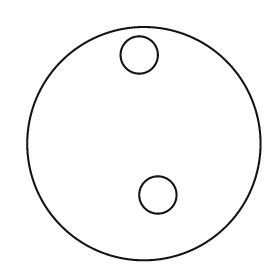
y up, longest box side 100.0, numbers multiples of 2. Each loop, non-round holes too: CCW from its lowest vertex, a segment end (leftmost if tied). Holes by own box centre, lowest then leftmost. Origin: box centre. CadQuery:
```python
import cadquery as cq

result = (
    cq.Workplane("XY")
    .moveTo(0.0, 0.0)
    .circle(50.0)
    .moveTo(6.0, -22.0)
    .circle(8.0)
    .moveTo(-2.0, 38.0)
    .circle(8.0)
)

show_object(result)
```